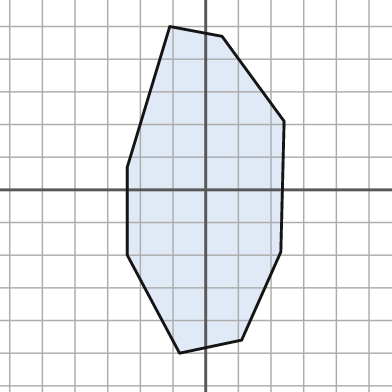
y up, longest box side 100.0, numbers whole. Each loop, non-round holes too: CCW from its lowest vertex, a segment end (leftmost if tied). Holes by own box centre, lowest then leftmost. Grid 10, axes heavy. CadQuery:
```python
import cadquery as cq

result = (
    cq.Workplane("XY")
    .moveTo(-8.0, -50.0)
    .lineTo(11.0, -46.0)
    .lineTo(23.0, -19.0)
    .lineTo(24.0, 21.0)
    .lineTo(5.0, 47.0)
    .lineTo(-11.0, 50.0)
    .lineTo(-24.0, 7.0)
    .lineTo(-24.0, -20.0)
    .close()
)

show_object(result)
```